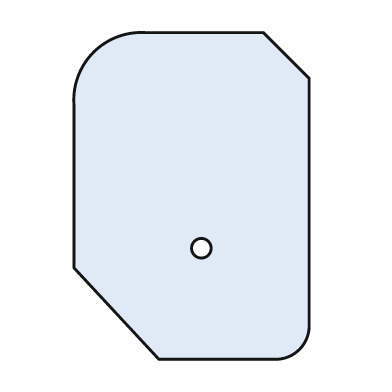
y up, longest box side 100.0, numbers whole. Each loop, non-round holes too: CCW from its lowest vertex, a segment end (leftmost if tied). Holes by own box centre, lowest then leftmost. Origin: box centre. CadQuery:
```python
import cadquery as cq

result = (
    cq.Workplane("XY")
    .moveTo(-10.0, -50.0)
    .lineTo(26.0, -50.0)
    .threePointArc((33.0, -47.0), (36.0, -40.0))
    .lineTo(36.0, 36.0)
    .lineTo(22.0, 50.0)
    .lineTo(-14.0, 50.0)
    .threePointArc((-30.0, 44.0), (-36.0, 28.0))
    .lineTo(-36.0, -22.0)
    .close()
    .moveTo(3.0, -16.0)
    .circle(3.0)
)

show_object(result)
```